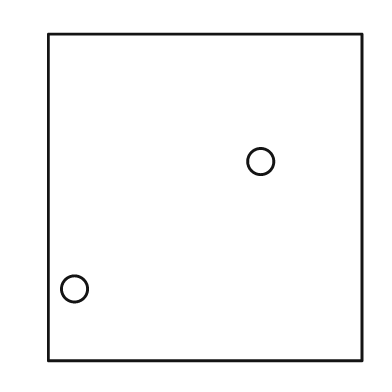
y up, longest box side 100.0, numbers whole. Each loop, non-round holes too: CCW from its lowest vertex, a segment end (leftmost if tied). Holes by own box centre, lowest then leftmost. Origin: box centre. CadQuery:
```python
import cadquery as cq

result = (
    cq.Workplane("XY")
    .moveTo(-48.0, -50.0)
    .lineTo(48.0, -50.0)
    .lineTo(48.0, 50.0)
    .lineTo(-48.0, 50.0)
    .close()
    .moveTo(-40.0, -28.0)
    .circle(4.0)
    .moveTo(17.0, 11.0)
    .circle(4.0)
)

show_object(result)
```